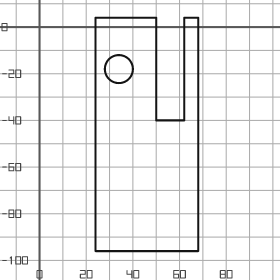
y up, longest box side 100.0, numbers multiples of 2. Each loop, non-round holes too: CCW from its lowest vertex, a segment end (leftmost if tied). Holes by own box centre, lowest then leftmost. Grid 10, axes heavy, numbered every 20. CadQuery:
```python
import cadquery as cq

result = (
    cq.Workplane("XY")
    .moveTo(24.0, -96.0)
    .lineTo(68.0, -96.0)
    .lineTo(68.0, 4.0)
    .lineTo(62.0, 4.0)
    .lineTo(62.0, -40.0)
    .lineTo(50.0, -40.0)
    .lineTo(50.0, 4.0)
    .lineTo(24.0, 4.0)
    .close()
    .moveTo(34.0, -18.0)
    .circle(6.0)
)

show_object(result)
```